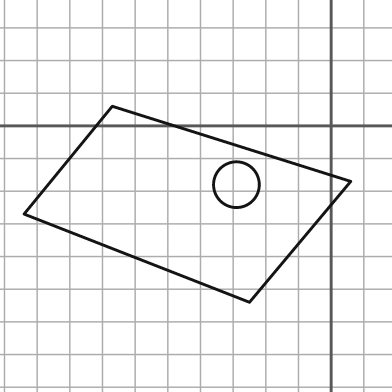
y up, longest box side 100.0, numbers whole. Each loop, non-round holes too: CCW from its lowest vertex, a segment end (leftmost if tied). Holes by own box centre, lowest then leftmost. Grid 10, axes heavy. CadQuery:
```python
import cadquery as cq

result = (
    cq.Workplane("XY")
    .moveTo(-25.0, -54.0)
    .lineTo(6.0, -17.0)
    .lineTo(-67.0, 6.0)
    .lineTo(-94.0, -27.0)
    .close()
    .moveTo(-29.0, -18.0)
    .circle(7.0)
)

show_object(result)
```